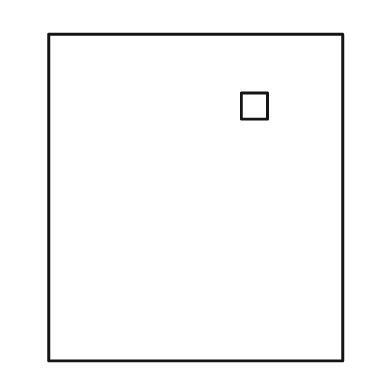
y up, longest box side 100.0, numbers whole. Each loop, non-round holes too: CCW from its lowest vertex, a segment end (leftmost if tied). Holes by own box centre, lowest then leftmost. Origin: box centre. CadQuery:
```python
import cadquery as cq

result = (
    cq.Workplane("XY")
    .moveTo(-45.0, -50.0)
    .lineTo(45.0, -50.0)
    .lineTo(45.0, 50.0)
    .lineTo(-45.0, 50.0)
    .close()
    .moveTo(14.0, 24.0)
    .lineTo(22.0, 24.0)
    .lineTo(22.0, 32.0)
    .lineTo(14.0, 32.0)
    .close()
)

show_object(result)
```